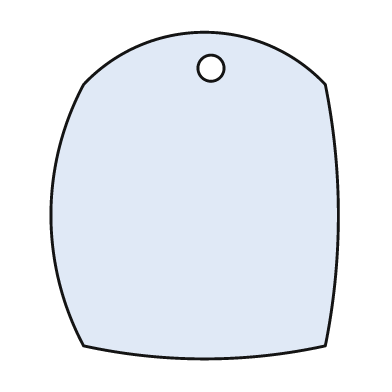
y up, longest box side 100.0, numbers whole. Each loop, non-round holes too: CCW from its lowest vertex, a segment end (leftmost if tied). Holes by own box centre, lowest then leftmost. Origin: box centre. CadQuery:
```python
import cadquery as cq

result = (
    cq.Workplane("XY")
    .moveTo(-34.0, -46.0)
    .threePointArc((3.0, -50.0), (40.0, -46.0))
    .threePointArc((44.0, -6.0), (40.0, 34.0))
    .threePointArc((3.0, 50.0), (-34.0, 34.0))
    .threePointArc((-44.0, -6.0), (-34.0, -46.0))
    .close()
    .moveTo(5.0, 39.0)
    .circle(4.0)
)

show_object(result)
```